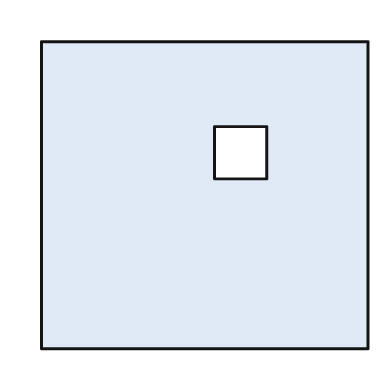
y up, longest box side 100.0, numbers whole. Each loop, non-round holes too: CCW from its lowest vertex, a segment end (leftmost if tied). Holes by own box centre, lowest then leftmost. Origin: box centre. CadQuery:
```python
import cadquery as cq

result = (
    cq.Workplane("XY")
    .moveTo(-50.0, -47.0)
    .lineTo(50.0, -47.0)
    .lineTo(50.0, 47.0)
    .lineTo(-50.0, 47.0)
    .close()
    .moveTo(3.0, 5.0)
    .lineTo(19.0, 5.0)
    .lineTo(19.0, 21.0)
    .lineTo(3.0, 21.0)
    .close()
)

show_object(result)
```